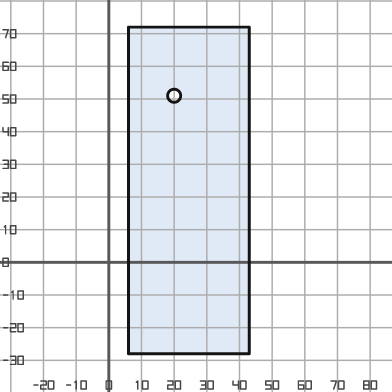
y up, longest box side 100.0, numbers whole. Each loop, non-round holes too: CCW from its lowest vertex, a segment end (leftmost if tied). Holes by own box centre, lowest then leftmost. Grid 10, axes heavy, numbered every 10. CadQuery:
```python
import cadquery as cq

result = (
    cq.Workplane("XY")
    .moveTo(6.0, -28.0)
    .lineTo(43.0, -28.0)
    .lineTo(43.0, 72.0)
    .lineTo(6.0, 72.0)
    .close()
    .moveTo(20.0, 51.0)
    .circle(2.0)
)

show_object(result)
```